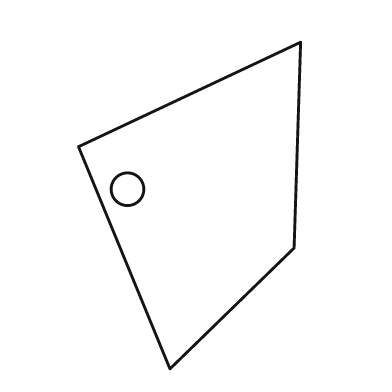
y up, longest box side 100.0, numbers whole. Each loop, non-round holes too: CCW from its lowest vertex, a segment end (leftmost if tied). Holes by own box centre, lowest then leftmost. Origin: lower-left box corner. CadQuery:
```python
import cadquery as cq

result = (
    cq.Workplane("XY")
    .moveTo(28.0, 0.0)
    .lineTo(66.0, 37.0)
    .lineTo(68.0, 100.0)
    .lineTo(0.0, 68.0)
    .close()
    .moveTo(15.0, 55.0)
    .circle(5.0)
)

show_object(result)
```